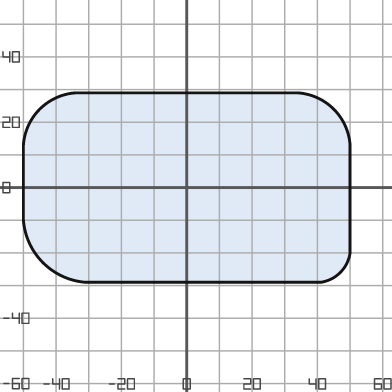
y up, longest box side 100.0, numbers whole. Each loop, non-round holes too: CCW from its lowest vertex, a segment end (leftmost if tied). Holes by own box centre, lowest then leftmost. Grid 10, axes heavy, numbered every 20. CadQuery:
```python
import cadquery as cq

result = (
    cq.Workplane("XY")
    .moveTo(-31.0, -29.0)
    .lineTo(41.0, -29.0)
    .threePointArc((47.0, -26.0), (50.0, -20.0))
    .lineTo(50.0, 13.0)
    .threePointArc((45.0, 24.0), (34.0, 29.0))
    .lineTo(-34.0, 29.0)
    .threePointArc((-45.0, 24.0), (-50.0, 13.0))
    .lineTo(-50.0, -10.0)
    .threePointArc((-44.0, -23.0), (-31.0, -29.0))
    .close()
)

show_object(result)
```